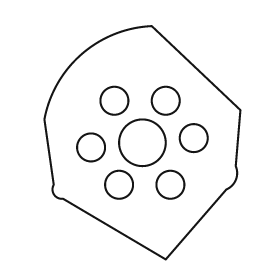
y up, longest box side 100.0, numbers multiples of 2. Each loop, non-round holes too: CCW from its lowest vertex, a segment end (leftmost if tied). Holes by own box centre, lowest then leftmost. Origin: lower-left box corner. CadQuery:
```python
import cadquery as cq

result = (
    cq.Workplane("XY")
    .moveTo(52.0, 0.0)
    .lineTo(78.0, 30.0)
    .threePointArc((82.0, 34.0), (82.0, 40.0))
    .lineTo(84.0, 64.0)
    .lineTo(46.0, 100.0)
    .threePointArc((16.0, 88.0), (0.0, 60.0))
    .lineTo(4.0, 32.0)
    .threePointArc((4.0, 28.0), (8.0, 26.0))
    .close()
    .moveTo(32.0, 32.0)
    .circle(6.0)
    .moveTo(54.0, 32.0)
    .circle(6.0)
    .moveTo(20.0, 48.0)
    .circle(6.0)
    .moveTo(42.0, 50.0)
    .circle(10.0)
    .moveTo(64.0, 52.0)
    .circle(6.0)
    .moveTo(30.0, 68.0)
    .circle(6.0)
    .moveTo(52.0, 68.0)
    .circle(6.0)
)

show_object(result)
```